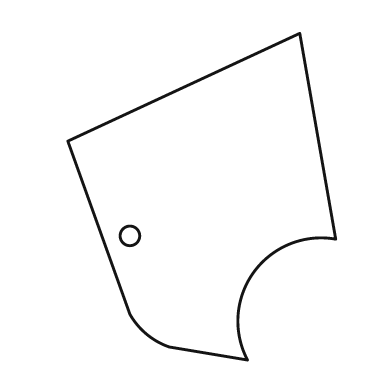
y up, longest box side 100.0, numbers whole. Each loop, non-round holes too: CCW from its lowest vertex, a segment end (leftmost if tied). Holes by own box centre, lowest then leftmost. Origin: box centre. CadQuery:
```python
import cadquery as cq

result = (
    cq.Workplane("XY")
    .moveTo(14.0, -50.0)
    .threePointArc((16.0, -23.0), (41.0, -13.0))
    .lineTo(30.0, 50.0)
    .lineTo(-41.0, 17.0)
    .lineTo(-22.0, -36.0)
    .threePointArc((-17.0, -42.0), (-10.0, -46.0))
    .close()
    .moveTo(-22.0, -12.0)
    .circle(3.0)
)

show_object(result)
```